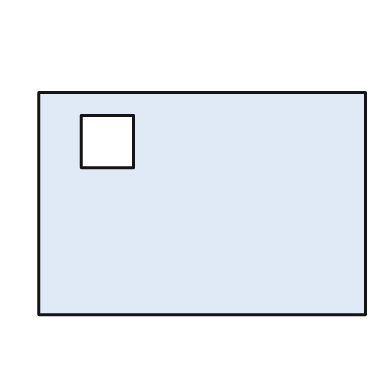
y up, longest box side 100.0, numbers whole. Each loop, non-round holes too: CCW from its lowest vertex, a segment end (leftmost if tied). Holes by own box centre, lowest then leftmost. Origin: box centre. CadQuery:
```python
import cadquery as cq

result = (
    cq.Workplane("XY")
    .moveTo(-50.0, -34.0)
    .lineTo(50.0, -34.0)
    .lineTo(50.0, 34.0)
    .lineTo(-50.0, 34.0)
    .close()
    .moveTo(-37.0, 11.0)
    .lineTo(-21.0, 11.0)
    .lineTo(-21.0, 27.0)
    .lineTo(-37.0, 27.0)
    .close()
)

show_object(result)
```